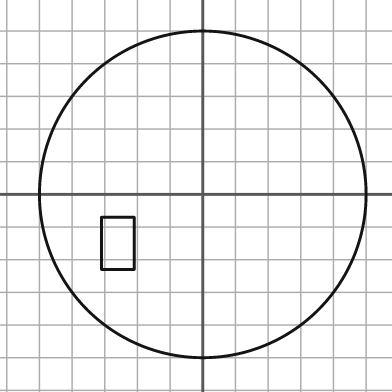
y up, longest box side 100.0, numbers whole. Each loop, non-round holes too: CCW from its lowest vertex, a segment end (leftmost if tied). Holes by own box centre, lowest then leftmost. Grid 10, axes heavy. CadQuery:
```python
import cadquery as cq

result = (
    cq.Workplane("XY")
    .moveTo(0.0, 0.0)
    .circle(50.0)
    .moveTo(-31.0, -23.0)
    .lineTo(-21.0, -23.0)
    .lineTo(-21.0, -7.0)
    .lineTo(-31.0, -7.0)
    .close()
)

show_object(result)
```